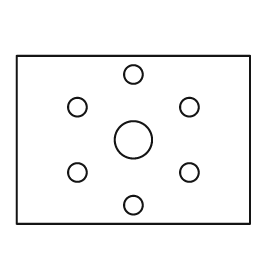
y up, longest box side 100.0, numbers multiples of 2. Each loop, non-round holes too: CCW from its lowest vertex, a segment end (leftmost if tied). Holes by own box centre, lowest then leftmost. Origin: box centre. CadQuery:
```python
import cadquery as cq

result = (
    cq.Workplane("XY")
    .moveTo(-50.0, -36.0)
    .lineTo(50.0, -36.0)
    .lineTo(50.0, 36.0)
    .lineTo(-50.0, 36.0)
    .close()
    .moveTo(0.0, -28.0)
    .circle(4.0)
    .moveTo(-24.0, -14.0)
    .circle(4.0)
    .moveTo(24.0, -14.0)
    .circle(4.0)
    .moveTo(0.0, 0.0)
    .circle(8.0)
    .moveTo(-24.0, 14.0)
    .circle(4.0)
    .moveTo(24.0, 14.0)
    .circle(4.0)
    .moveTo(0.0, 28.0)
    .circle(4.0)
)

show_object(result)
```